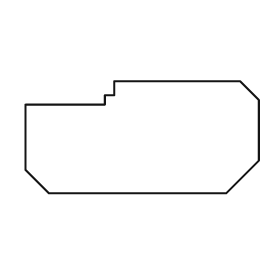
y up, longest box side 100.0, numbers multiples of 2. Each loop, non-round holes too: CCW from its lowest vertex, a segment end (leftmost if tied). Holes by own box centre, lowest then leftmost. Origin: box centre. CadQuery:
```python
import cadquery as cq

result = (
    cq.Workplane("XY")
    .moveTo(-40.0, -24.0)
    .lineTo(36.0, -24.0)
    .lineTo(50.0, -10.0)
    .lineTo(50.0, 16.0)
    .lineTo(42.0, 24.0)
    .lineTo(-12.0, 24.0)
    .lineTo(-12.0, 18.0)
    .lineTo(-16.0, 18.0)
    .lineTo(-16.0, 14.0)
    .lineTo(-50.0, 14.0)
    .lineTo(-50.0, -14.0)
    .close()
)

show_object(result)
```